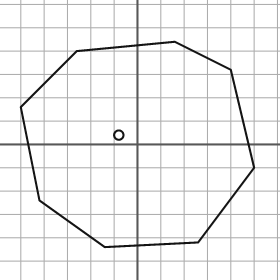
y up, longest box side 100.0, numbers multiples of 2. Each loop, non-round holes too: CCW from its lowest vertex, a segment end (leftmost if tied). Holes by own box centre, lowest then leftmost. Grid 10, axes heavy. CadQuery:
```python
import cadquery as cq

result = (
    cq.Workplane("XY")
    .moveTo(-14.0, -44.0)
    .lineTo(26.0, -42.0)
    .lineTo(50.0, -10.0)
    .lineTo(40.0, 32.0)
    .lineTo(16.0, 44.0)
    .lineTo(-26.0, 40.0)
    .lineTo(-50.0, 16.0)
    .lineTo(-42.0, -24.0)
    .close()
    .moveTo(-8.0, 4.0)
    .circle(2.0)
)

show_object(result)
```